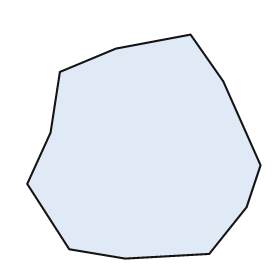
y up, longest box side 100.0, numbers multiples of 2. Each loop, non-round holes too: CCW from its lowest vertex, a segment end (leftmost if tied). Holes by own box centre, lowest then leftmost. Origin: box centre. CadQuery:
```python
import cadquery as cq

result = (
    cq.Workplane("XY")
    .moveTo(-8.0, -48.0)
    .lineTo(28.0, -46.0)
    .lineTo(44.0, -26.0)
    .lineTo(50.0, -8.0)
    .lineTo(34.0, 28.0)
    .lineTo(20.0, 48.0)
    .lineTo(-12.0, 42.0)
    .lineTo(-36.0, 32.0)
    .lineTo(-40.0, 6.0)
    .lineTo(-50.0, -16.0)
    .lineTo(-32.0, -44.0)
    .close()
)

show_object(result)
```